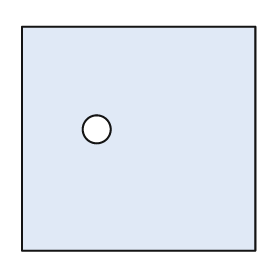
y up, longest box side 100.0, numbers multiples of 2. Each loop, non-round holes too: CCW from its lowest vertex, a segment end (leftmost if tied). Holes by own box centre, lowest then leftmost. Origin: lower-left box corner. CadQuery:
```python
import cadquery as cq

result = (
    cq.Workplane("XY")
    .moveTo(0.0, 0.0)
    .lineTo(100.0, 0.0)
    .lineTo(100.0, 96.0)
    .lineTo(0.0, 96.0)
    .close()
    .moveTo(32.0, 52.0)
    .circle(6.0)
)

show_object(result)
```